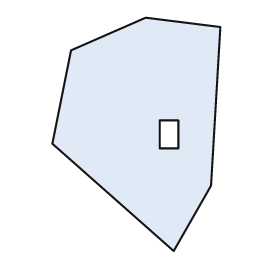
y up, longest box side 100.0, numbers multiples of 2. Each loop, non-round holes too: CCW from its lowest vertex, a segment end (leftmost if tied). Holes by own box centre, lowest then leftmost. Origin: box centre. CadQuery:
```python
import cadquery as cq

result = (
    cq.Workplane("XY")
    .moveTo(16.0, -50.0)
    .lineTo(32.0, -22.0)
    .lineTo(36.0, 46.0)
    .lineTo(4.0, 50.0)
    .lineTo(-28.0, 36.0)
    .lineTo(-36.0, -4.0)
    .close()
    .moveTo(10.0, -6.0)
    .lineTo(18.0, -6.0)
    .lineTo(18.0, 6.0)
    .lineTo(10.0, 6.0)
    .close()
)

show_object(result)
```